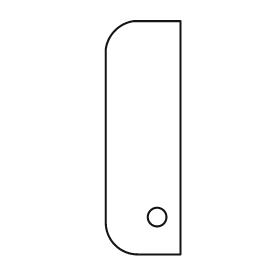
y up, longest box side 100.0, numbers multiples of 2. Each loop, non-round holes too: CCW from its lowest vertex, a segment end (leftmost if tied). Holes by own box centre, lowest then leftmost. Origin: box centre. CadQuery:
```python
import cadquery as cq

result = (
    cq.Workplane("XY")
    .moveTo(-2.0, -50.0)
    .lineTo(16.0, -50.0)
    .lineTo(16.0, 50.0)
    .lineTo(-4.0, 50.0)
    .threePointArc((-12.0, 46.0), (-16.0, 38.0))
    .lineTo(-16.0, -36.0)
    .threePointArc((-12.0, -46.0), (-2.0, -50.0))
    .close()
    .moveTo(6.0, -34.0)
    .circle(4.0)
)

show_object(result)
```